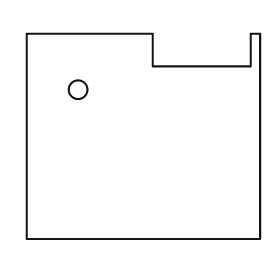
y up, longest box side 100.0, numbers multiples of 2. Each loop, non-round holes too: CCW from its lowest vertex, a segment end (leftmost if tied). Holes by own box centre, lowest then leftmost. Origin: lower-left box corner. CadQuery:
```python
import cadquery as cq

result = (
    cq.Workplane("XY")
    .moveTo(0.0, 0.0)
    .lineTo(100.0, 0.0)
    .lineTo(100.0, 88.0)
    .lineTo(96.0, 88.0)
    .lineTo(96.0, 74.0)
    .lineTo(54.0, 74.0)
    .lineTo(54.0, 88.0)
    .lineTo(0.0, 88.0)
    .close()
    .moveTo(22.0, 64.0)
    .circle(4.0)
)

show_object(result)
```